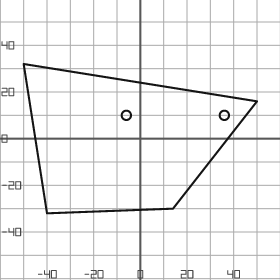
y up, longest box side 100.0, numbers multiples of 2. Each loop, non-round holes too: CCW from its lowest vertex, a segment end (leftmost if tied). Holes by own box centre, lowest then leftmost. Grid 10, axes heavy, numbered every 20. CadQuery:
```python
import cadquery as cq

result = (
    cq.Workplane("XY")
    .moveTo(-40.0, -32.0)
    .lineTo(14.0, -30.0)
    .lineTo(50.0, 16.0)
    .lineTo(-50.0, 32.0)
    .close()
    .moveTo(-6.0, 10.0)
    .circle(2.0)
    .moveTo(36.0, 10.0)
    .circle(2.0)
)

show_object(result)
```